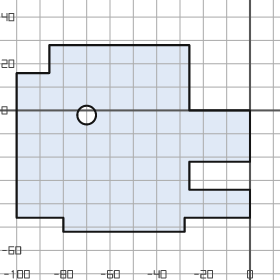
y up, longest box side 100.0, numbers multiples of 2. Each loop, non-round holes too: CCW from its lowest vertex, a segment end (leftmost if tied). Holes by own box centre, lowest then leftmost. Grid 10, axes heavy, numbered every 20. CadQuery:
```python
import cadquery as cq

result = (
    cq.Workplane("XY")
    .moveTo(-80.0, -52.0)
    .lineTo(-28.0, -52.0)
    .lineTo(-28.0, -46.0)
    .lineTo(0.0, -46.0)
    .lineTo(0.0, -34.0)
    .lineTo(-26.0, -34.0)
    .lineTo(-26.0, -22.0)
    .lineTo(0.0, -22.0)
    .lineTo(0.0, 0.0)
    .lineTo(-26.0, 0.0)
    .lineTo(-26.0, 28.0)
    .lineTo(-86.0, 28.0)
    .lineTo(-86.0, 16.0)
    .lineTo(-100.0, 16.0)
    .lineTo(-100.0, -46.0)
    .lineTo(-80.0, -46.0)
    .close()
    .moveTo(-70.0, -2.0)
    .circle(4.0)
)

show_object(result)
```